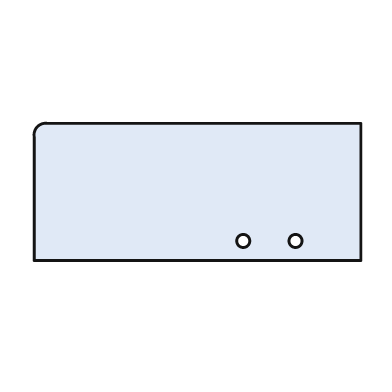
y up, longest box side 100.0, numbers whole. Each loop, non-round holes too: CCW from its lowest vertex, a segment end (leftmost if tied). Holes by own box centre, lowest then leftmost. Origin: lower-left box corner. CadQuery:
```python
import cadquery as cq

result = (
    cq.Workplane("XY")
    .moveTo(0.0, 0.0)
    .lineTo(100.0, 0.0)
    .lineTo(100.0, 42.0)
    .lineTo(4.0, 42.0)
    .threePointArc((1.0, 41.0), (0.0, 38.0))
    .close()
    .moveTo(64.0, 6.0)
    .circle(2.0)
    .moveTo(80.0, 6.0)
    .circle(2.0)
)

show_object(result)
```